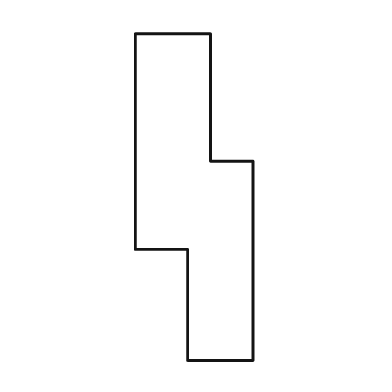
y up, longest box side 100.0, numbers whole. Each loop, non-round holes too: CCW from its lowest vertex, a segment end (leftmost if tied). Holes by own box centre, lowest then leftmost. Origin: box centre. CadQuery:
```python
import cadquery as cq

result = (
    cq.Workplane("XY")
    .moveTo(-2.0, -50.0)
    .lineTo(18.0, -50.0)
    .lineTo(18.0, 11.0)
    .lineTo(5.0, 11.0)
    .lineTo(5.0, 50.0)
    .lineTo(-18.0, 50.0)
    .lineTo(-18.0, -16.0)
    .lineTo(-2.0, -16.0)
    .close()
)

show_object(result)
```